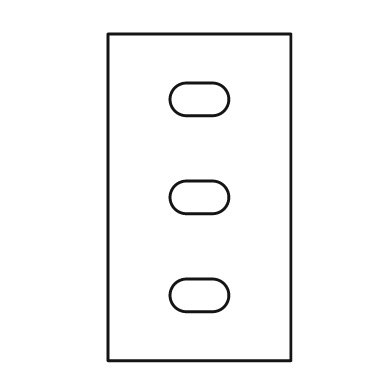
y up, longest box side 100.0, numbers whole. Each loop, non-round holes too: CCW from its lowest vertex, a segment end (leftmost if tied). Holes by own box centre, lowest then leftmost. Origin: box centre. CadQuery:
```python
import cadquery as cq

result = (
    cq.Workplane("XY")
    .moveTo(-28.0, -50.0)
    .lineTo(28.0, -50.0)
    .lineTo(28.0, 50.0)
    .lineTo(-28.0, 50.0)
    .close()
    .moveTo(-4.0, -35.0)
    .lineTo(4.0, -35.0)
    .threePointArc((9.0, -30.0), (4.0, -25.0))
    .lineTo(-4.0, -25.0)
    .threePointArc((-9.0, -30.0), (-4.0, -35.0))
    .close()
    .moveTo(-4.0, -5.0)
    .lineTo(4.0, -5.0)
    .threePointArc((9.0, 0.0), (4.0, 5.0))
    .lineTo(-4.0, 5.0)
    .threePointArc((-9.0, 0.0), (-4.0, -5.0))
    .close()
    .moveTo(-4.0, 25.0)
    .lineTo(4.0, 25.0)
    .threePointArc((9.0, 30.0), (4.0, 35.0))
    .lineTo(-4.0, 35.0)
    .threePointArc((-9.0, 30.0), (-4.0, 25.0))
    .close()
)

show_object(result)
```